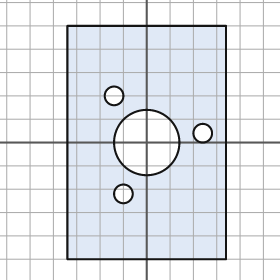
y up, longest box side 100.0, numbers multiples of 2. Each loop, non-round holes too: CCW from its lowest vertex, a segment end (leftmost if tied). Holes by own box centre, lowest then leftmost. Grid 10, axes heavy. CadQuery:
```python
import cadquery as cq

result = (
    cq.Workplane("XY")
    .moveTo(-34.0, -50.0)
    .lineTo(34.0, -50.0)
    .lineTo(34.0, 50.0)
    .lineTo(-34.0, 50.0)
    .close()
    .moveTo(-10.0, -22.0)
    .circle(4.0)
    .moveTo(0.0, 0.0)
    .circle(14.0)
    .moveTo(24.0, 4.0)
    .circle(4.0)
    .moveTo(-14.0, 20.0)
    .circle(4.0)
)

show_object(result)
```